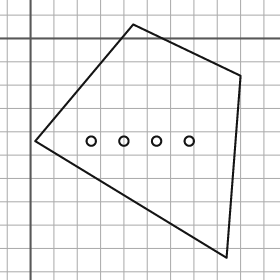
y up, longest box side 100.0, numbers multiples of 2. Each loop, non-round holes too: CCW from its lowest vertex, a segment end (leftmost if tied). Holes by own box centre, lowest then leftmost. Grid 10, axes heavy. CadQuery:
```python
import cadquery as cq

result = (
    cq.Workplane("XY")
    .moveTo(84.0, -94.0)
    .lineTo(90.0, -16.0)
    .lineTo(44.0, 6.0)
    .lineTo(2.0, -44.0)
    .close()
    .moveTo(26.0, -44.0)
    .circle(2.0)
    .moveTo(40.0, -44.0)
    .circle(2.0)
    .moveTo(54.0, -44.0)
    .circle(2.0)
    .moveTo(68.0, -44.0)
    .circle(2.0)
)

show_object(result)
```